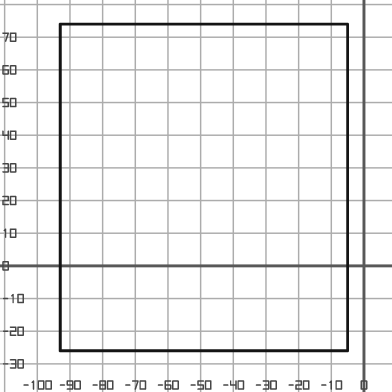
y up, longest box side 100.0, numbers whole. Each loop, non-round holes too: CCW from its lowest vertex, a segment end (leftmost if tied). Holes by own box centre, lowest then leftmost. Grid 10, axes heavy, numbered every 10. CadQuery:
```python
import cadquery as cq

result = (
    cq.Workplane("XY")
    .moveTo(-93.0, -26.0)
    .lineTo(-5.0, -26.0)
    .lineTo(-5.0, 74.0)
    .lineTo(-93.0, 74.0)
    .close()
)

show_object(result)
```